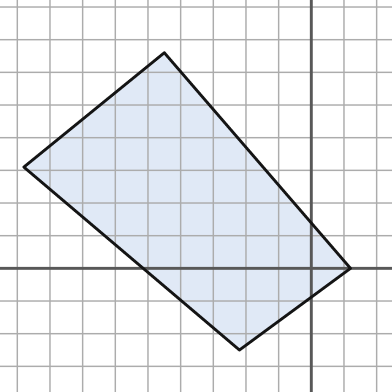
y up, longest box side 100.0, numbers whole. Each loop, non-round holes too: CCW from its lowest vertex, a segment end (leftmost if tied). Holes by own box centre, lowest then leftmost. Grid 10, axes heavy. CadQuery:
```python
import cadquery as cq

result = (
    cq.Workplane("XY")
    .moveTo(-22.0, -25.0)
    .lineTo(12.0, 0.0)
    .lineTo(-45.0, 66.0)
    .lineTo(-88.0, 31.0)
    .close()
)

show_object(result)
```